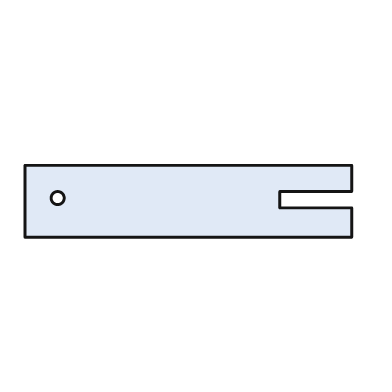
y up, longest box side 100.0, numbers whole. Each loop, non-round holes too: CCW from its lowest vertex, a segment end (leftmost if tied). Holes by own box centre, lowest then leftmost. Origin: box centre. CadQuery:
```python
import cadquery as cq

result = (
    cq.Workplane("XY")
    .moveTo(-50.0, -11.0)
    .lineTo(50.0, -11.0)
    .lineTo(50.0, -2.0)
    .lineTo(28.0, -2.0)
    .lineTo(28.0, 3.0)
    .lineTo(50.0, 3.0)
    .lineTo(50.0, 11.0)
    .lineTo(-50.0, 11.0)
    .close()
    .moveTo(-40.0, 1.0)
    .circle(2.0)
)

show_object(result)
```